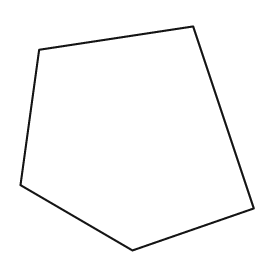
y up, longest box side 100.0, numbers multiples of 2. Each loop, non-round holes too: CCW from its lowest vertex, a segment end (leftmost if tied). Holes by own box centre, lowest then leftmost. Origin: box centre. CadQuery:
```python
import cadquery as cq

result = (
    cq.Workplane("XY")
    .moveTo(-2.0, -48.0)
    .lineTo(50.0, -30.0)
    .lineTo(24.0, 48.0)
    .lineTo(-42.0, 38.0)
    .lineTo(-50.0, -20.0)
    .close()
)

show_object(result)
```